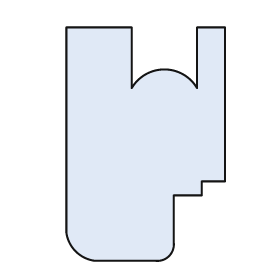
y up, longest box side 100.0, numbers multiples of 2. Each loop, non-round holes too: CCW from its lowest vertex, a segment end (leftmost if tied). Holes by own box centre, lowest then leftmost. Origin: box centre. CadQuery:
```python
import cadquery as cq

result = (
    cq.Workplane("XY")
    .moveTo(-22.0, -50.0)
    .lineTo(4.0, -50.0)
    .threePointArc((10.0, -48.0), (12.0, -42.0))
    .lineTo(12.0, -22.0)
    .lineTo(24.0, -22.0)
    .lineTo(24.0, -16.0)
    .lineTo(34.0, -16.0)
    .lineTo(34.0, 50.0)
    .lineTo(22.0, 50.0)
    .lineTo(22.0, 24.0)
    .threePointArc((8.0, 32.0), (-6.0, 24.0))
    .lineTo(-6.0, 50.0)
    .lineTo(-34.0, 50.0)
    .lineTo(-34.0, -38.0)
    .threePointArc((-30.0, -46.0), (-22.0, -50.0))
    .close()
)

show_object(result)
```